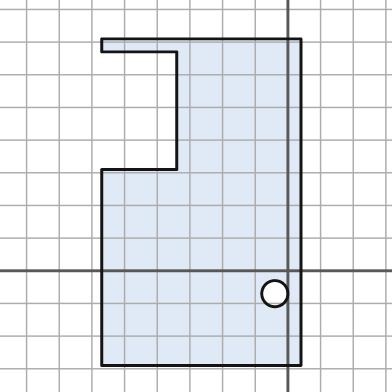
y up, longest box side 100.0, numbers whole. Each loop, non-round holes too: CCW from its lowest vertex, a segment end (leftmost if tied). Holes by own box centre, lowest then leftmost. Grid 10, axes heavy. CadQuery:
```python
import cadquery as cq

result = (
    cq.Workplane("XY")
    .moveTo(-57.0, -29.0)
    .lineTo(4.0, -29.0)
    .lineTo(4.0, 71.0)
    .lineTo(-57.0, 71.0)
    .lineTo(-57.0, 67.0)
    .lineTo(-34.0, 67.0)
    .lineTo(-34.0, 31.0)
    .lineTo(-57.0, 31.0)
    .close()
    .moveTo(-4.0, -7.0)
    .circle(4.0)
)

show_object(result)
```